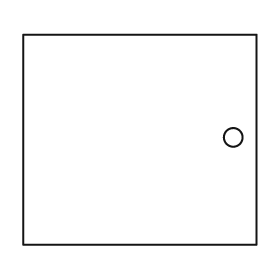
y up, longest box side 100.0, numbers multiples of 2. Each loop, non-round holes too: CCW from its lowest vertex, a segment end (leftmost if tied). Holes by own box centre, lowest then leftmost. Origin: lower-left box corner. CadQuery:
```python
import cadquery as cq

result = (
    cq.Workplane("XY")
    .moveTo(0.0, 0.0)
    .lineTo(100.0, 0.0)
    .lineTo(100.0, 90.0)
    .lineTo(0.0, 90.0)
    .close()
    .moveTo(90.0, 46.0)
    .circle(4.0)
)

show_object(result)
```